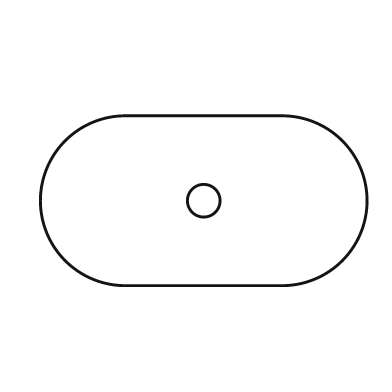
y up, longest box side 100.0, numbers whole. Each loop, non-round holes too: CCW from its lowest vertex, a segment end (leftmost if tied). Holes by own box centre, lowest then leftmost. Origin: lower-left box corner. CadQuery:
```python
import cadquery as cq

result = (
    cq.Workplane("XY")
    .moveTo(26.0, 0.0)
    .lineTo(74.0, 0.0)
    .threePointArc((100.0, 26.0), (74.0, 52.0))
    .lineTo(26.0, 52.0)
    .threePointArc((0.0, 26.0), (26.0, 0.0))
    .close()
    .moveTo(50.0, 26.0)
    .circle(5.0)
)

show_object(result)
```